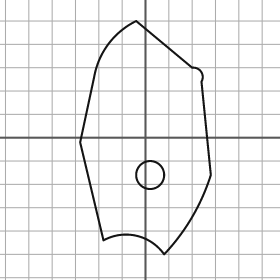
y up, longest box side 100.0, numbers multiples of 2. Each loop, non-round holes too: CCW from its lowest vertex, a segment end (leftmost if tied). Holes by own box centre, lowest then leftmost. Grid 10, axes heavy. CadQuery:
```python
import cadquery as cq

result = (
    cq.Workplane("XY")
    .moveTo(8.0, -50.0)
    .threePointArc((20.0, -34.0), (28.0, -16.0))
    .lineTo(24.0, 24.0)
    .threePointArc((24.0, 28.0), (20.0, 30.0))
    .lineTo(-4.0, 50.0)
    .threePointArc((-16.0, 40.0), (-22.0, 26.0))
    .lineTo(-28.0, -2.0)
    .lineTo(-18.0, -44.0)
    .threePointArc((-4.0, -42.0), (8.0, -50.0))
    .close()
    .moveTo(2.0, -16.0)
    .circle(6.0)
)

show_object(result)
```